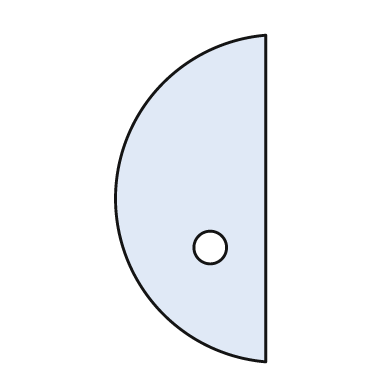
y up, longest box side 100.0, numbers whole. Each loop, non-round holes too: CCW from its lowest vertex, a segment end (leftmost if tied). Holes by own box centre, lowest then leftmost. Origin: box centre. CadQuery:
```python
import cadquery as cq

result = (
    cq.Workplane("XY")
    .moveTo(23.0, -50.0)
    .lineTo(23.0, 50.0)
    .threePointArc((-23.0, 0.0), (23.0, -50.0))
    .close()
    .moveTo(6.0, -15.0)
    .circle(5.0)
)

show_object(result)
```